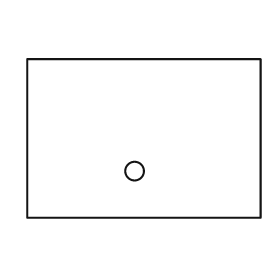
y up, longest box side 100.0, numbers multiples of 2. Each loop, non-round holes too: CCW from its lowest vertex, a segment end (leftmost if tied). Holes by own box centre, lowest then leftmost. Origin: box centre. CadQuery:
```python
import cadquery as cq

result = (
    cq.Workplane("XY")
    .moveTo(-50.0, -34.0)
    .lineTo(50.0, -34.0)
    .lineTo(50.0, 34.0)
    .lineTo(-50.0, 34.0)
    .close()
    .moveTo(-4.0, -14.0)
    .circle(4.0)
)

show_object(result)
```